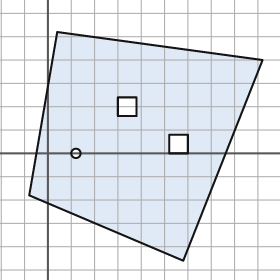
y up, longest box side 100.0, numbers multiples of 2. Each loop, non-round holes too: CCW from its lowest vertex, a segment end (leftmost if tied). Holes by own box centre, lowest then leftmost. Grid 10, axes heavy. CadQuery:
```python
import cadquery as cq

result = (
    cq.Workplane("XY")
    .moveTo(58.0, -46.0)
    .lineTo(92.0, 40.0)
    .lineTo(4.0, 52.0)
    .lineTo(-8.0, -18.0)
    .close()
    .moveTo(12.0, 0.0)
    .circle(2.0)
    .moveTo(52.0, 0.0)
    .lineTo(60.0, 0.0)
    .lineTo(60.0, 8.0)
    .lineTo(52.0, 8.0)
    .close()
    .moveTo(30.0, 16.0)
    .lineTo(38.0, 16.0)
    .lineTo(38.0, 24.0)
    .lineTo(30.0, 24.0)
    .close()
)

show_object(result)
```